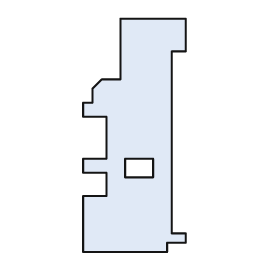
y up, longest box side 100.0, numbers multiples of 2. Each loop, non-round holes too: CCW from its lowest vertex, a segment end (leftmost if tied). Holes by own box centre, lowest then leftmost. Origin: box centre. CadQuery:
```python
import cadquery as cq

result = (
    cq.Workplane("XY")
    .moveTo(-22.0, -50.0)
    .lineTo(14.0, -50.0)
    .lineTo(14.0, -46.0)
    .lineTo(22.0, -46.0)
    .lineTo(22.0, -42.0)
    .lineTo(16.0, -42.0)
    .lineTo(16.0, 36.0)
    .lineTo(22.0, 36.0)
    .lineTo(22.0, 50.0)
    .lineTo(-6.0, 50.0)
    .lineTo(-6.0, 24.0)
    .lineTo(-14.0, 24.0)
    .lineTo(-18.0, 20.0)
    .lineTo(-18.0, 14.0)
    .lineTo(-22.0, 14.0)
    .lineTo(-22.0, 8.0)
    .lineTo(-12.0, 8.0)
    .lineTo(-12.0, -10.0)
    .lineTo(-22.0, -10.0)
    .lineTo(-22.0, -16.0)
    .lineTo(-12.0, -16.0)
    .lineTo(-12.0, -26.0)
    .lineTo(-22.0, -26.0)
    .close()
    .moveTo(-4.0, -18.0)
    .lineTo(8.0, -18.0)
    .lineTo(8.0, -10.0)
    .lineTo(-4.0, -10.0)
    .close()
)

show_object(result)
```